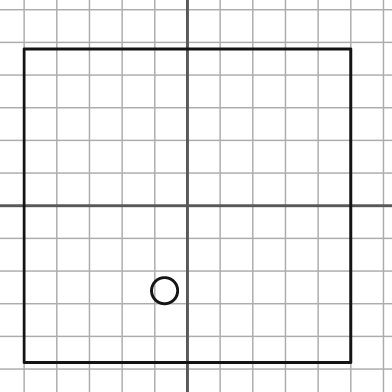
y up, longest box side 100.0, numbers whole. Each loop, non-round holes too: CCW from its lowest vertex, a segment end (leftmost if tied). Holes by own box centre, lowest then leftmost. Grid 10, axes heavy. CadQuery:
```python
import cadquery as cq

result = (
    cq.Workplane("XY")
    .moveTo(-50.0, -48.0)
    .lineTo(50.0, -48.0)
    .lineTo(50.0, 48.0)
    .lineTo(-50.0, 48.0)
    .close()
    .moveTo(-7.0, -26.0)
    .circle(4.0)
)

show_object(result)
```